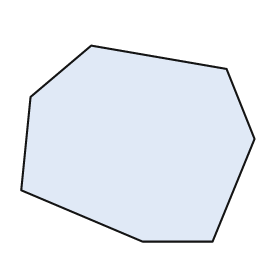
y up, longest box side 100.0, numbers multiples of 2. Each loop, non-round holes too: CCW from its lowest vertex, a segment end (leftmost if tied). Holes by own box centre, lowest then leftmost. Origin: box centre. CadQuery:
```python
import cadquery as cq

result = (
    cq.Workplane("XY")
    .moveTo(2.0, -42.0)
    .lineTo(32.0, -42.0)
    .lineTo(50.0, 2.0)
    .lineTo(38.0, 32.0)
    .lineTo(-20.0, 42.0)
    .lineTo(-46.0, 20.0)
    .lineTo(-50.0, -20.0)
    .close()
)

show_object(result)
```